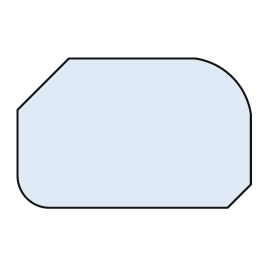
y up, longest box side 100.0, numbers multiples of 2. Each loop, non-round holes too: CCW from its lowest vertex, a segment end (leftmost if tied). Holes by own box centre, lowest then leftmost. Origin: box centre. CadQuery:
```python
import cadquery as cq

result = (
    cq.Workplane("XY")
    .moveTo(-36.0, -32.0)
    .lineTo(40.0, -32.0)
    .lineTo(50.0, -22.0)
    .lineTo(50.0, 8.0)
    .threePointArc((42.0, 24.0), (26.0, 32.0))
    .lineTo(-28.0, 32.0)
    .lineTo(-50.0, 10.0)
    .lineTo(-50.0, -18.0)
    .threePointArc((-46.0, -28.0), (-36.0, -32.0))
    .close()
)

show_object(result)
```